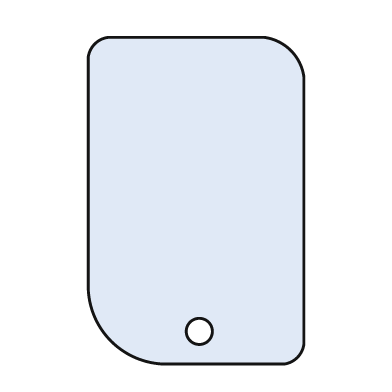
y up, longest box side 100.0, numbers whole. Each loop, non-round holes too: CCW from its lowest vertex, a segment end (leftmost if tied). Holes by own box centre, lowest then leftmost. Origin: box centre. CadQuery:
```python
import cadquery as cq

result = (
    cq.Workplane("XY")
    .moveTo(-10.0, -50.0)
    .lineTo(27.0, -50.0)
    .threePointArc((31.0, -48.0), (33.0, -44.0))
    .lineTo(33.0, 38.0)
    .threePointArc((29.0, 46.0), (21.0, 50.0))
    .lineTo(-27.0, 50.0)
    .threePointArc((-31.0, 48.0), (-33.0, 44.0))
    .lineTo(-33.0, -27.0)
    .threePointArc((-26.0, -43.0), (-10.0, -50.0))
    .close()
    .moveTo(1.0, -40.0)
    .circle(4.0)
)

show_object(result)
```